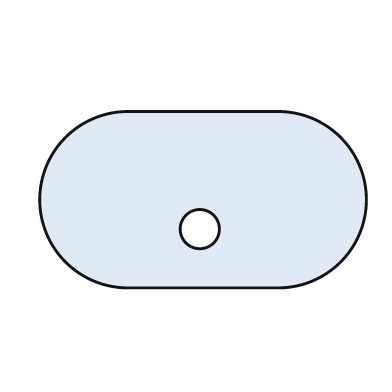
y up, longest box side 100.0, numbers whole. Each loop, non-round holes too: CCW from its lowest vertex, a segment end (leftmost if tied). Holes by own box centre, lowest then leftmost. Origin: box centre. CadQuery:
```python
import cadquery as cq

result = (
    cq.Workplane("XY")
    .moveTo(-23.0, -27.0)
    .lineTo(23.0, -27.0)
    .threePointArc((50.0, 0.0), (23.0, 27.0))
    .lineTo(-23.0, 27.0)
    .threePointArc((-50.0, 0.0), (-23.0, -27.0))
    .close()
    .moveTo(-1.0, -9.0)
    .circle(6.0)
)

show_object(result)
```